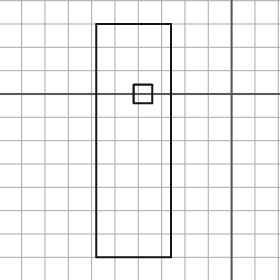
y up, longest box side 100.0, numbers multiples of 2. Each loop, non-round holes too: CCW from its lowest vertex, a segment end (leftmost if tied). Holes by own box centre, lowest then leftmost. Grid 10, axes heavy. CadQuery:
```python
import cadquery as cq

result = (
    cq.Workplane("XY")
    .moveTo(-58.0, -70.0)
    .lineTo(-26.0, -70.0)
    .lineTo(-26.0, 30.0)
    .lineTo(-58.0, 30.0)
    .close()
    .moveTo(-42.0, -4.0)
    .lineTo(-34.0, -4.0)
    .lineTo(-34.0, 4.0)
    .lineTo(-42.0, 4.0)
    .close()
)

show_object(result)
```